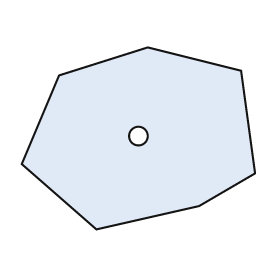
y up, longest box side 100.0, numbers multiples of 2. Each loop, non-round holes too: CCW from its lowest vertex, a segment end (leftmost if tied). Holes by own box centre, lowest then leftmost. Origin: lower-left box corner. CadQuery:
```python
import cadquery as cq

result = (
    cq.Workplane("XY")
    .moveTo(32.0, 0.0)
    .lineTo(76.0, 10.0)
    .lineTo(100.0, 24.0)
    .lineTo(94.0, 68.0)
    .lineTo(54.0, 78.0)
    .lineTo(16.0, 66.0)
    .lineTo(0.0, 28.0)
    .close()
    .moveTo(50.0, 40.0)
    .circle(4.0)
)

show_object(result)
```